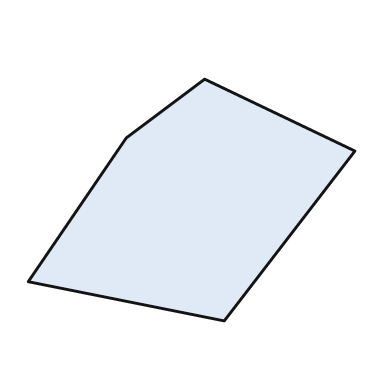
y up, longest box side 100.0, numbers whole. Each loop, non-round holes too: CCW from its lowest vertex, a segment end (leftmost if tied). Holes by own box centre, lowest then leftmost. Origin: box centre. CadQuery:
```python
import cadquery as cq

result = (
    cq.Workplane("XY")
    .moveTo(10.0, -37.0)
    .lineTo(50.0, 15.0)
    .lineTo(4.0, 37.0)
    .lineTo(-20.0, 19.0)
    .lineTo(-50.0, -25.0)
    .close()
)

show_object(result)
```